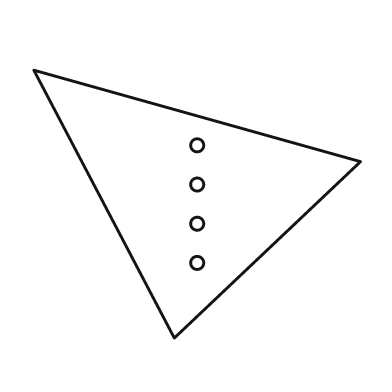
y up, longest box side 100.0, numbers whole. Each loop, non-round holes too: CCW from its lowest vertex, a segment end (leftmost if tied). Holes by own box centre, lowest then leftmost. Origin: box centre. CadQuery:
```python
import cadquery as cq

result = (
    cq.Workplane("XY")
    .moveTo(-7.0, -41.0)
    .lineTo(50.0, 13.0)
    .lineTo(-50.0, 41.0)
    .close()
    .moveTo(0.0, -18.0)
    .circle(2.0)
    .moveTo(0.0, -6.0)
    .circle(2.0)
    .moveTo(0.0, 6.0)
    .circle(2.0)
    .moveTo(0.0, 18.0)
    .circle(2.0)
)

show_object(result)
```